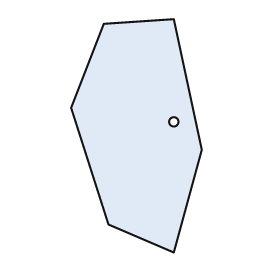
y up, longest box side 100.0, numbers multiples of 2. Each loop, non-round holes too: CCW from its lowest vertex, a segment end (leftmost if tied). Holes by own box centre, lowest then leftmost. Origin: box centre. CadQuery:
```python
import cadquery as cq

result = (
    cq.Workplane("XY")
    .moveTo(16.0, -50.0)
    .lineTo(28.0, -6.0)
    .lineTo(16.0, 50.0)
    .lineTo(-14.0, 48.0)
    .lineTo(-28.0, 12.0)
    .lineTo(-12.0, -38.0)
    .close()
    .moveTo(16.0, 6.0)
    .circle(2.0)
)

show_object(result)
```